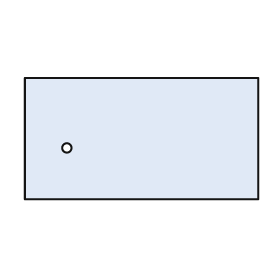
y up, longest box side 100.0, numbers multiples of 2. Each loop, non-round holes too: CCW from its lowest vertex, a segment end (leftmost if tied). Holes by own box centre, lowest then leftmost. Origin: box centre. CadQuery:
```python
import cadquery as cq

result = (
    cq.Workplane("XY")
    .moveTo(-50.0, -26.0)
    .lineTo(50.0, -26.0)
    .lineTo(50.0, 26.0)
    .lineTo(-50.0, 26.0)
    .close()
    .moveTo(-32.0, -4.0)
    .circle(2.0)
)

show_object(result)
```